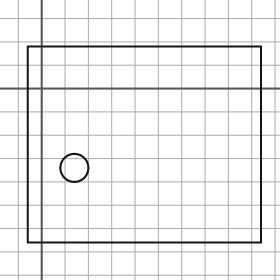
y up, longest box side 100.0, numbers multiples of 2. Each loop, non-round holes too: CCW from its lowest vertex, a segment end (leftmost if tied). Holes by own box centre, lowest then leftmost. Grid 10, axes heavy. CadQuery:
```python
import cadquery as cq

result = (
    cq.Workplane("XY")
    .moveTo(-6.0, -66.0)
    .lineTo(94.0, -66.0)
    .lineTo(94.0, 18.0)
    .lineTo(-6.0, 18.0)
    .close()
    .moveTo(14.0, -34.0)
    .circle(6.0)
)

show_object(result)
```